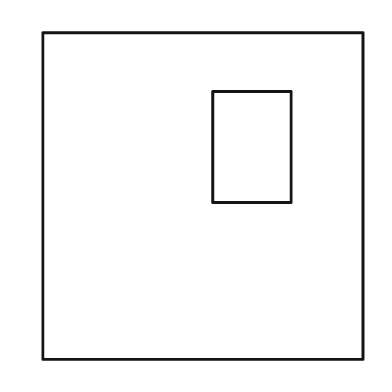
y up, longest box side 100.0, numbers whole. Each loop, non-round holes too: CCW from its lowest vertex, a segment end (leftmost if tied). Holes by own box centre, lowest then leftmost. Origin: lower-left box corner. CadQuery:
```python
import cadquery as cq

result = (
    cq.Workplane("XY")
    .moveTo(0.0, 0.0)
    .lineTo(98.0, 0.0)
    .lineTo(98.0, 100.0)
    .lineTo(0.0, 100.0)
    .close()
    .moveTo(52.0, 48.0)
    .lineTo(76.0, 48.0)
    .lineTo(76.0, 82.0)
    .lineTo(52.0, 82.0)
    .close()
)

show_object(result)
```